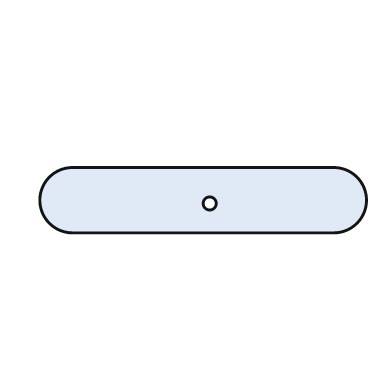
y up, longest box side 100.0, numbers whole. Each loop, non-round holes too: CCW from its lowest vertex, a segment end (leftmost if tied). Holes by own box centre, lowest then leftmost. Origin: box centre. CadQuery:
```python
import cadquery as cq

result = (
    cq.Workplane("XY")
    .moveTo(-40.0, -10.0)
    .lineTo(40.0, -10.0)
    .threePointArc((50.0, 0.0), (40.0, 10.0))
    .lineTo(-40.0, 10.0)
    .threePointArc((-50.0, 0.0), (-40.0, -10.0))
    .close()
    .moveTo(2.0, -1.0)
    .circle(2.0)
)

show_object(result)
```